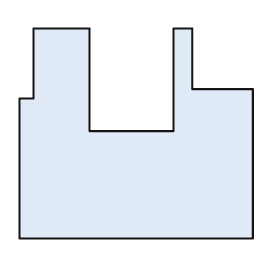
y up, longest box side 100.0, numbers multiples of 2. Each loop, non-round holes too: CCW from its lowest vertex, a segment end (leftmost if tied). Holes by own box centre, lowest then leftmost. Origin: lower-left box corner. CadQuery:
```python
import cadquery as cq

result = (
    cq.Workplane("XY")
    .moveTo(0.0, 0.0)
    .lineTo(100.0, 0.0)
    .lineTo(100.0, 64.0)
    .lineTo(74.0, 64.0)
    .lineTo(74.0, 90.0)
    .lineTo(66.0, 90.0)
    .lineTo(66.0, 46.0)
    .lineTo(30.0, 46.0)
    .lineTo(30.0, 90.0)
    .lineTo(6.0, 90.0)
    .lineTo(6.0, 60.0)
    .lineTo(0.0, 60.0)
    .close()
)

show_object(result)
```